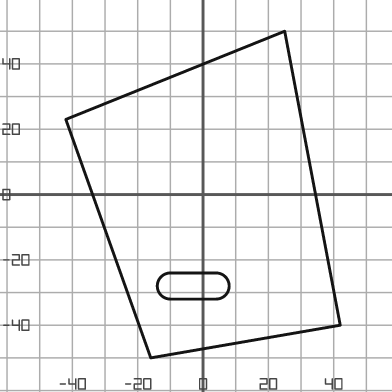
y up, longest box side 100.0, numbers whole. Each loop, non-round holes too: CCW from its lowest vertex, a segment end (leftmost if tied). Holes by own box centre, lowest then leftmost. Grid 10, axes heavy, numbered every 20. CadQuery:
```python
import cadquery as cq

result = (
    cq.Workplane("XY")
    .moveTo(-16.0, -50.0)
    .lineTo(42.0, -40.0)
    .lineTo(25.0, 50.0)
    .lineTo(-42.0, 23.0)
    .close()
    .moveTo(-10.0, -32.0)
    .lineTo(4.0, -32.0)
    .threePointArc((8.0, -28.0), (4.0, -24.0))
    .lineTo(-10.0, -24.0)
    .threePointArc((-14.0, -28.0), (-10.0, -32.0))
    .close()
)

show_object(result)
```